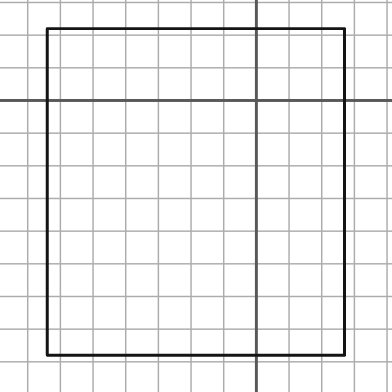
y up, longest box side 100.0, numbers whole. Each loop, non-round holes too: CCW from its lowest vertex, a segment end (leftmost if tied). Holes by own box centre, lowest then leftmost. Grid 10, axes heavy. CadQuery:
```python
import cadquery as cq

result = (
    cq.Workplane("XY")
    .moveTo(-64.0, -78.0)
    .lineTo(27.0, -78.0)
    .lineTo(27.0, 22.0)
    .lineTo(-64.0, 22.0)
    .close()
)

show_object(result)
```